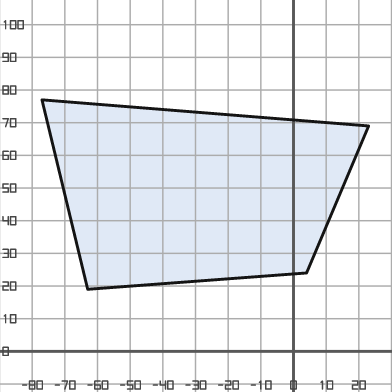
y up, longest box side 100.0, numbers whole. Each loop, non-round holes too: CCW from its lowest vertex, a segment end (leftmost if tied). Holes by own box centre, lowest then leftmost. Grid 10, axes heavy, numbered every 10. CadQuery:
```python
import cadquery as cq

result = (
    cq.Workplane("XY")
    .moveTo(-63.0, 19.0)
    .lineTo(4.0, 24.0)
    .lineTo(23.0, 69.0)
    .lineTo(-77.0, 77.0)
    .close()
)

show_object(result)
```